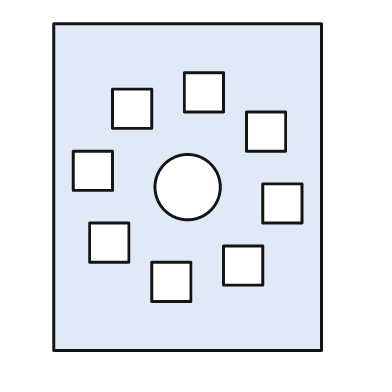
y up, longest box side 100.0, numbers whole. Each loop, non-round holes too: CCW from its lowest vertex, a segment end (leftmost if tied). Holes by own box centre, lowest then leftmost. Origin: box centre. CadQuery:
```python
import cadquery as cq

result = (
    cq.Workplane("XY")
    .moveTo(-41.0, -50.0)
    .lineTo(41.0, -50.0)
    .lineTo(41.0, 50.0)
    .lineTo(-41.0, 50.0)
    .close()
    .moveTo(-11.0, -35.0)
    .lineTo(1.0, -35.0)
    .lineTo(1.0, -23.0)
    .lineTo(-11.0, -23.0)
    .close()
    .moveTo(11.0, -30.0)
    .lineTo(23.0, -30.0)
    .lineTo(23.0, -18.0)
    .lineTo(11.0, -18.0)
    .close()
    .moveTo(-30.0, -23.0)
    .lineTo(-18.0, -23.0)
    .lineTo(-18.0, -11.0)
    .lineTo(-30.0, -11.0)
    .close()
    .moveTo(23.0, -11.0)
    .lineTo(35.0, -11.0)
    .lineTo(35.0, 1.0)
    .lineTo(23.0, 1.0)
    .close()
    .moveTo(0.0, 0.0)
    .circle(10.0)
    .moveTo(-35.0, -1.0)
    .lineTo(-23.0, -1.0)
    .lineTo(-23.0, 11.0)
    .lineTo(-35.0, 11.0)
    .close()
    .moveTo(18.0, 11.0)
    .lineTo(30.0, 11.0)
    .lineTo(30.0, 23.0)
    .lineTo(18.0, 23.0)
    .close()
    .moveTo(-23.0, 18.0)
    .lineTo(-11.0, 18.0)
    .lineTo(-11.0, 30.0)
    .lineTo(-23.0, 30.0)
    .close()
    .moveTo(-1.0, 23.0)
    .lineTo(11.0, 23.0)
    .lineTo(11.0, 35.0)
    .lineTo(-1.0, 35.0)
    .close()
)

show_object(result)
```